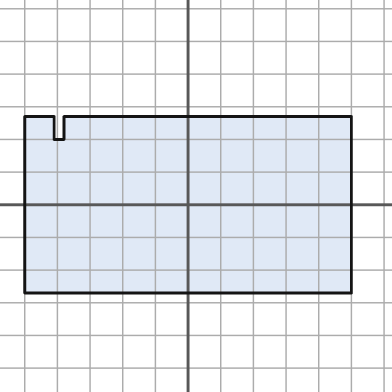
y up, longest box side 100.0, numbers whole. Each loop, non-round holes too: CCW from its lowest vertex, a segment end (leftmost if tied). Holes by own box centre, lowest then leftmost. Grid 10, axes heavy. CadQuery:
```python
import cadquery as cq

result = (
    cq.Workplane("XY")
    .moveTo(-50.0, -27.0)
    .lineTo(50.0, -27.0)
    .lineTo(50.0, 27.0)
    .lineTo(-38.0, 27.0)
    .lineTo(-38.0, 20.0)
    .lineTo(-41.0, 20.0)
    .lineTo(-41.0, 27.0)
    .lineTo(-50.0, 27.0)
    .close()
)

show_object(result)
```